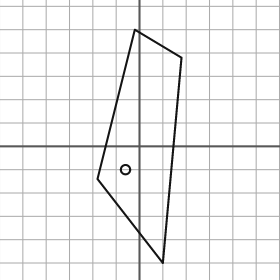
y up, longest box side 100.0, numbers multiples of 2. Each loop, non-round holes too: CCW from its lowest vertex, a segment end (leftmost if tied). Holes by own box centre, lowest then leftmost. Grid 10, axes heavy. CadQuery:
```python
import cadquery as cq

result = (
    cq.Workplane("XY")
    .moveTo(10.0, -50.0)
    .lineTo(18.0, 38.0)
    .lineTo(-2.0, 50.0)
    .lineTo(-18.0, -14.0)
    .close()
    .moveTo(-6.0, -10.0)
    .circle(2.0)
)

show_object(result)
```